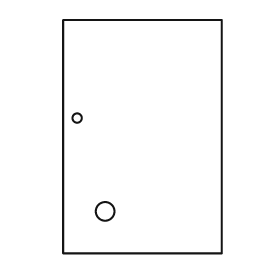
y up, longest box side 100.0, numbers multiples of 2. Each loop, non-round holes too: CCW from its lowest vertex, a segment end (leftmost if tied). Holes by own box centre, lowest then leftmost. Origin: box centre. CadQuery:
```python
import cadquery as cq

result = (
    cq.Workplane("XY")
    .moveTo(-34.0, -50.0)
    .lineTo(34.0, -50.0)
    .lineTo(34.0, 50.0)
    .lineTo(-34.0, 50.0)
    .close()
    .moveTo(-16.0, -32.0)
    .circle(4.0)
    .moveTo(-28.0, 8.0)
    .circle(2.0)
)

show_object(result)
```